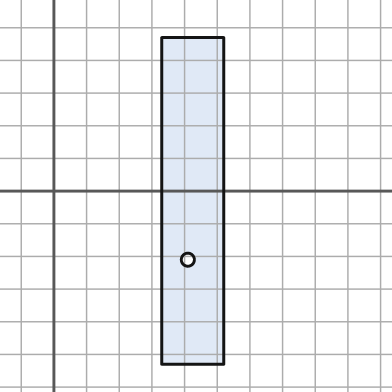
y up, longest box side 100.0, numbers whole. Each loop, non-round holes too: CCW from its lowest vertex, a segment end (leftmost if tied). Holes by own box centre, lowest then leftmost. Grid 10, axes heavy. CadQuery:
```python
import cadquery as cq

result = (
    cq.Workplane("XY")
    .moveTo(33.0, -53.0)
    .lineTo(52.0, -53.0)
    .lineTo(52.0, 47.0)
    .lineTo(33.0, 47.0)
    .close()
    .moveTo(41.0, -21.0)
    .circle(2.0)
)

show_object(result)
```